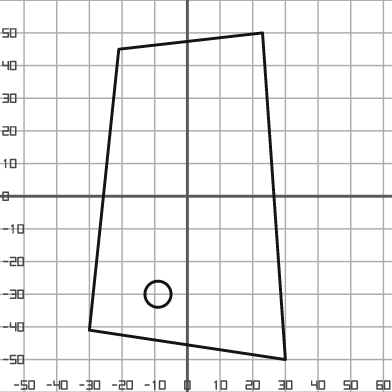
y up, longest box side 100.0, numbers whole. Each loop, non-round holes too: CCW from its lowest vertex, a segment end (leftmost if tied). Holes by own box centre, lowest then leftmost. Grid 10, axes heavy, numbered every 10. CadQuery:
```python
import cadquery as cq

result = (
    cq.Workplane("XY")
    .moveTo(30.0, -50.0)
    .lineTo(23.0, 50.0)
    .lineTo(-21.0, 45.0)
    .lineTo(-30.0, -41.0)
    .close()
    .moveTo(-9.0, -30.0)
    .circle(4.0)
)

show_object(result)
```